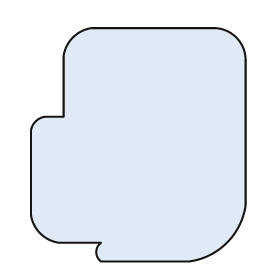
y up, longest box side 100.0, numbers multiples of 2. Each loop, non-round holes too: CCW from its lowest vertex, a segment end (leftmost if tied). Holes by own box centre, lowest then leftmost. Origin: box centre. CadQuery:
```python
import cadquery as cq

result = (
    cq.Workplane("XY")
    .moveTo(-16.0, -50.0)
    .lineTo(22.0, -50.0)
    .threePointArc((38.0, -42.0), (46.0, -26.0))
    .lineTo(46.0, 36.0)
    .threePointArc((42.0, 46.0), (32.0, 50.0))
    .lineTo(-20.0, 50.0)
    .threePointArc((-28.0, 46.0), (-32.0, 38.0))
    .lineTo(-32.0, 12.0)
    .lineTo(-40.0, 12.0)
    .threePointArc((-44.0, 10.0), (-46.0, 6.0))
    .lineTo(-46.0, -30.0)
    .threePointArc((-42.0, -38.0), (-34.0, -42.0))
    .lineTo(-16.0, -42.0)
    .threePointArc((-18.0, -46.0), (-16.0, -50.0))
    .close()
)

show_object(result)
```